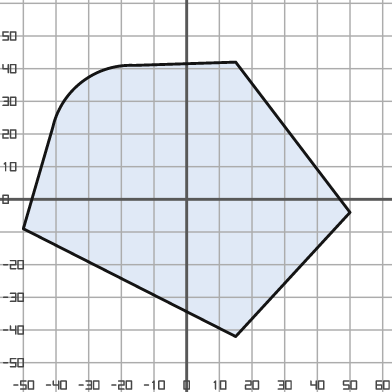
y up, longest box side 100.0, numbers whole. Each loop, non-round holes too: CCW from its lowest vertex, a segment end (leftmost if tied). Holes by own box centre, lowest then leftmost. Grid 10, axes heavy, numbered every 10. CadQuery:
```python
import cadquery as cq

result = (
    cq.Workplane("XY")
    .moveTo(15.0, -42.0)
    .lineTo(50.0, -4.0)
    .lineTo(15.0, 42.0)
    .lineTo(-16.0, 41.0)
    .threePointArc((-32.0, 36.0), (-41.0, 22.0))
    .lineTo(-50.0, -9.0)
    .close()
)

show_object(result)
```